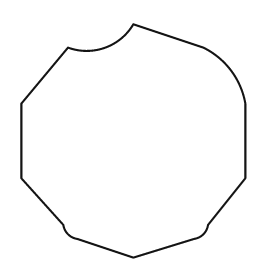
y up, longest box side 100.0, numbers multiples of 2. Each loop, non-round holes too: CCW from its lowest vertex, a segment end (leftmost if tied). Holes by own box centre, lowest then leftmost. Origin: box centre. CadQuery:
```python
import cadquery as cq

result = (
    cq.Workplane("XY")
    .moveTo(0.0, -50.0)
    .lineTo(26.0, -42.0)
    .threePointArc((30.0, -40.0), (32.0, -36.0))
    .lineTo(48.0, -16.0)
    .lineTo(48.0, 16.0)
    .threePointArc((42.0, 30.0), (30.0, 40.0))
    .lineTo(0.0, 50.0)
    .threePointArc((-12.0, 40.0), (-28.0, 40.0))
    .lineTo(-48.0, 16.0)
    .lineTo(-48.0, -16.0)
    .lineTo(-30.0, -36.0)
    .threePointArc((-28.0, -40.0), (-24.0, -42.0))
    .close()
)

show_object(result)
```